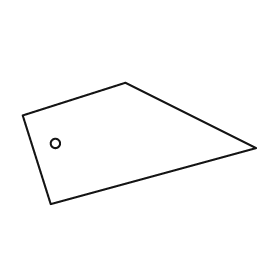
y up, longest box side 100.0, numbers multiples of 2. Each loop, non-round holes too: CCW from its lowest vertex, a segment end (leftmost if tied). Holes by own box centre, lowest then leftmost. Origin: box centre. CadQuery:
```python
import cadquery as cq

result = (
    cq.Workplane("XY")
    .moveTo(-38.0, -26.0)
    .lineTo(50.0, -2.0)
    .lineTo(-6.0, 26.0)
    .lineTo(-50.0, 12.0)
    .close()
    .moveTo(-36.0, 0.0)
    .circle(2.0)
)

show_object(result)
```